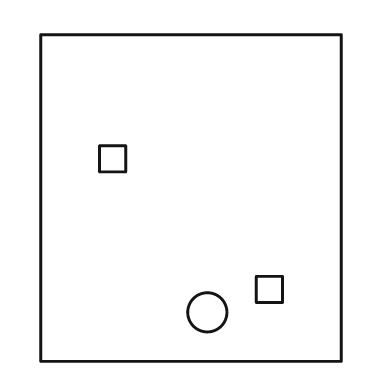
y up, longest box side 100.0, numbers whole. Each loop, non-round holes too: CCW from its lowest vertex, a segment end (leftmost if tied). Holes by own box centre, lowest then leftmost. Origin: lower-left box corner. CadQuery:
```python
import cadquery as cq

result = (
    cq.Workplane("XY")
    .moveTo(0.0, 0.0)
    .lineTo(92.0, 0.0)
    .lineTo(92.0, 100.0)
    .lineTo(0.0, 100.0)
    .close()
    .moveTo(51.0, 15.0)
    .circle(6.0)
    .moveTo(66.0, 18.0)
    .lineTo(74.0, 18.0)
    .lineTo(74.0, 26.0)
    .lineTo(66.0, 26.0)
    .close()
    .moveTo(18.0, 58.0)
    .lineTo(26.0, 58.0)
    .lineTo(26.0, 66.0)
    .lineTo(18.0, 66.0)
    .close()
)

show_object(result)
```